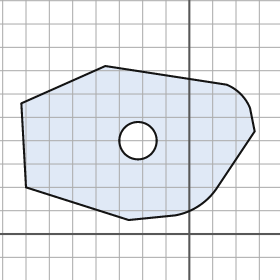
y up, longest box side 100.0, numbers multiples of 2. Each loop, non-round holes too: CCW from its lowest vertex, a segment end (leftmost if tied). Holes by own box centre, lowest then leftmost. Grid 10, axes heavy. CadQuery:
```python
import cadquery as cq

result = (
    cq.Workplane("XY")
    .moveTo(-26.0, 6.0)
    .lineTo(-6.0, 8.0)
    .threePointArc((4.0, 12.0), (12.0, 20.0))
    .lineTo(28.0, 44.0)
    .lineTo(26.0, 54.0)
    .threePointArc((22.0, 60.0), (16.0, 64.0))
    .lineTo(-36.0, 72.0)
    .lineTo(-72.0, 56.0)
    .lineTo(-70.0, 20.0)
    .close()
    .moveTo(-22.0, 40.0)
    .circle(8.0)
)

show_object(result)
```